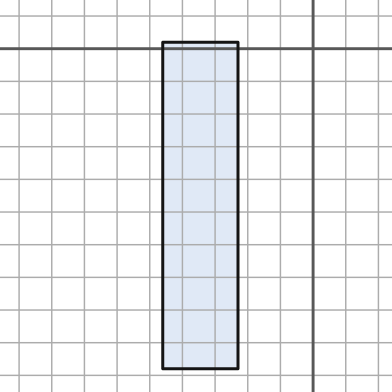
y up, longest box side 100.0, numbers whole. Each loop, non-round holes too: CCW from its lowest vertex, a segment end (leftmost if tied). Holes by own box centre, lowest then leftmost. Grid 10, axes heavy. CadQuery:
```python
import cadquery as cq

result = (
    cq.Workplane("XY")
    .moveTo(-46.0, -98.0)
    .lineTo(-23.0, -98.0)
    .lineTo(-23.0, 2.0)
    .lineTo(-46.0, 2.0)
    .close()
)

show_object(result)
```